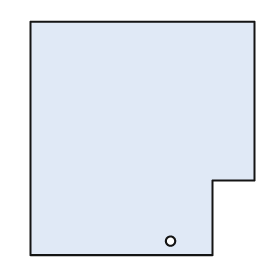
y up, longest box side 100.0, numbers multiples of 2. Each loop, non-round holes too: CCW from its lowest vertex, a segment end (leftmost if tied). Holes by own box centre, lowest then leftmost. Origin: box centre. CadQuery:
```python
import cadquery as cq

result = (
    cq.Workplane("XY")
    .moveTo(-48.0, -50.0)
    .lineTo(30.0, -50.0)
    .lineTo(30.0, -18.0)
    .lineTo(48.0, -18.0)
    .lineTo(48.0, 50.0)
    .lineTo(-48.0, 50.0)
    .close()
    .moveTo(12.0, -44.0)
    .circle(2.0)
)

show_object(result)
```